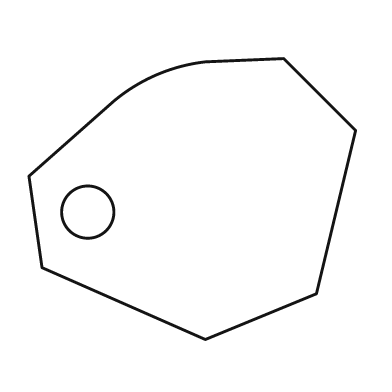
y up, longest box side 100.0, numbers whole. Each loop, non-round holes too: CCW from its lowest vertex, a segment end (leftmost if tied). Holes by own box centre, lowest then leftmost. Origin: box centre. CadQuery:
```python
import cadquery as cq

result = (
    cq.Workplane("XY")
    .moveTo(4.0, -43.0)
    .lineTo(38.0, -29.0)
    .lineTo(50.0, 21.0)
    .lineTo(28.0, 43.0)
    .lineTo(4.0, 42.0)
    .threePointArc((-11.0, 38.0), (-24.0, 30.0))
    .lineTo(-50.0, 7.0)
    .lineTo(-46.0, -21.0)
    .close()
    .moveTo(-32.0, -4.0)
    .circle(8.0)
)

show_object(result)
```